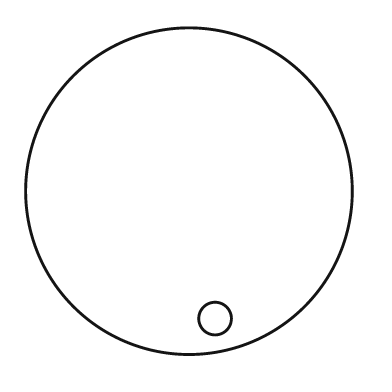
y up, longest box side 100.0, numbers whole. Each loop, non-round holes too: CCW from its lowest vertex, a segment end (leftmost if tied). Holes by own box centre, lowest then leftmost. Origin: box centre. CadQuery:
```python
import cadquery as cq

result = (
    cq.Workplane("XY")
    .moveTo(0.0, 0.0)
    .circle(50.0)
    .moveTo(8.0, -39.0)
    .circle(5.0)
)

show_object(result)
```